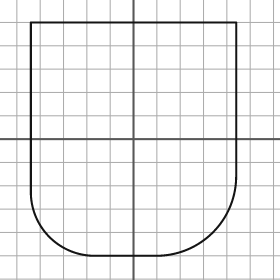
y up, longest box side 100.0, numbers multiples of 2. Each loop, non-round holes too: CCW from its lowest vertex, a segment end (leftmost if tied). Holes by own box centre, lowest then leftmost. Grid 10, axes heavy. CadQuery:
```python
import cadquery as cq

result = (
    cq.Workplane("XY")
    .moveTo(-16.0, -50.0)
    .lineTo(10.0, -50.0)
    .threePointArc((34.0, -40.0), (44.0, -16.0))
    .lineTo(44.0, 50.0)
    .lineTo(-44.0, 50.0)
    .lineTo(-44.0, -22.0)
    .threePointArc((-36.0, -42.0), (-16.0, -50.0))
    .close()
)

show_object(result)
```